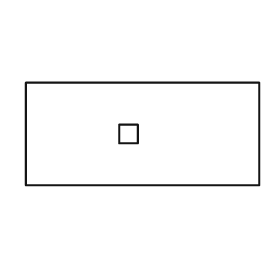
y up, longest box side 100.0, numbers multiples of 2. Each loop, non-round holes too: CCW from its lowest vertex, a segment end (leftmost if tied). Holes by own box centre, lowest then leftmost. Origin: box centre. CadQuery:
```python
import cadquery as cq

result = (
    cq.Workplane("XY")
    .moveTo(-50.0, -22.0)
    .lineTo(50.0, -22.0)
    .lineTo(50.0, 22.0)
    .lineTo(-50.0, 22.0)
    .close()
    .moveTo(-10.0, -4.0)
    .lineTo(-2.0, -4.0)
    .lineTo(-2.0, 4.0)
    .lineTo(-10.0, 4.0)
    .close()
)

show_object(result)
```